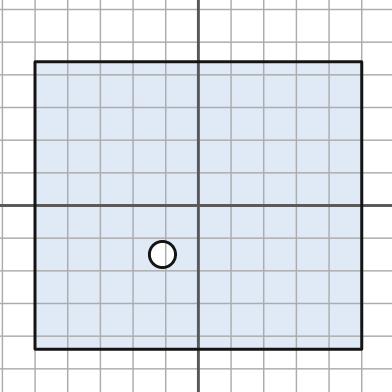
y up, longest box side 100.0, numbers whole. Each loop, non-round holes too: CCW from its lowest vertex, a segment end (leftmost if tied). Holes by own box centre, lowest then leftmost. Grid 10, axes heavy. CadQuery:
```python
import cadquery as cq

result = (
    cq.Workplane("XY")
    .moveTo(-50.0, -44.0)
    .lineTo(50.0, -44.0)
    .lineTo(50.0, 44.0)
    .lineTo(-50.0, 44.0)
    .close()
    .moveTo(-11.0, -15.0)
    .circle(4.0)
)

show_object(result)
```